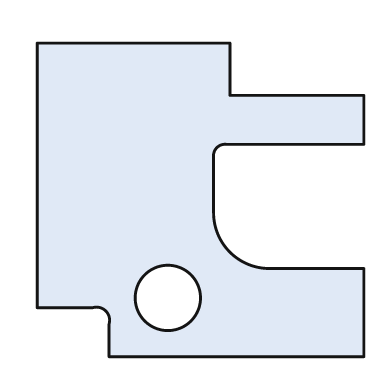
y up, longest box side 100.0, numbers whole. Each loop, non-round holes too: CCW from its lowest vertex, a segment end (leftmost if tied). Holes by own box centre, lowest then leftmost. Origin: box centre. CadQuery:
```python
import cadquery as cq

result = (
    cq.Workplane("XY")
    .moveTo(-28.0, -48.0)
    .lineTo(50.0, -48.0)
    .lineTo(50.0, -21.0)
    .lineTo(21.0, -21.0)
    .threePointArc((9.0, -16.0), (4.0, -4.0))
    .lineTo(4.0, 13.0)
    .threePointArc((5.0, 16.0), (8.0, 17.0))
    .lineTo(50.0, 17.0)
    .lineTo(50.0, 32.0)
    .lineTo(9.0, 32.0)
    .lineTo(9.0, 48.0)
    .lineTo(-50.0, 48.0)
    .lineTo(-50.0, -33.0)
    .lineTo(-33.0, -33.0)
    .threePointArc((-29.0, -34.0), (-28.0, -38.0))
    .close()
    .moveTo(-10.0, -30.0)
    .circle(10.0)
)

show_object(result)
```